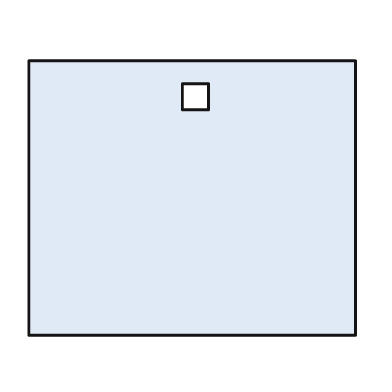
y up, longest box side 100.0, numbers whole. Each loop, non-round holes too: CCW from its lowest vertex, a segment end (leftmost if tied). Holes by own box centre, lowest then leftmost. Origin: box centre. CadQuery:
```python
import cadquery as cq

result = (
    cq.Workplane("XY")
    .moveTo(-50.0, -42.0)
    .lineTo(50.0, -42.0)
    .lineTo(50.0, 42.0)
    .lineTo(-50.0, 42.0)
    .close()
    .moveTo(-3.0, 27.0)
    .lineTo(5.0, 27.0)
    .lineTo(5.0, 35.0)
    .lineTo(-3.0, 35.0)
    .close()
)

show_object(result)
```